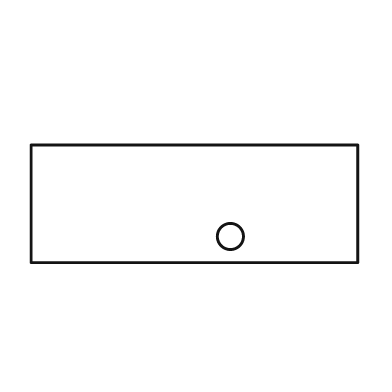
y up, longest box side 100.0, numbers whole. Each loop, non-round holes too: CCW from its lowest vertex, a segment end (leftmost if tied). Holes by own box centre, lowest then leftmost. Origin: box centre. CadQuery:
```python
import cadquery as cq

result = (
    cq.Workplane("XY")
    .moveTo(-50.0, -18.0)
    .lineTo(50.0, -18.0)
    .lineTo(50.0, 18.0)
    .lineTo(-50.0, 18.0)
    .close()
    .moveTo(11.0, -10.0)
    .circle(4.0)
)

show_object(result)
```